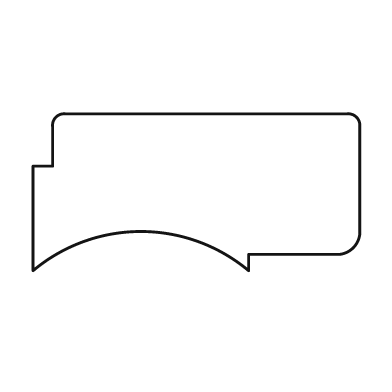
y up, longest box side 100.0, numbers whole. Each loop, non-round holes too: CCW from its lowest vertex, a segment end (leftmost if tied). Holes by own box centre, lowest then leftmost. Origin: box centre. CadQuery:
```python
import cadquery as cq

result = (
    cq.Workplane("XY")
    .moveTo(-50.0, -24.0)
    .threePointArc((-17.0, -12.0), (16.0, -24.0))
    .lineTo(16.0, -19.0)
    .lineTo(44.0, -19.0)
    .threePointArc((48.0, -17.0), (50.0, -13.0))
    .lineTo(50.0, 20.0)
    .threePointArc((49.0, 23.0), (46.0, 24.0))
    .lineTo(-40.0, 24.0)
    .threePointArc((-43.0, 23.0), (-44.0, 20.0))
    .lineTo(-44.0, 8.0)
    .lineTo(-50.0, 8.0)
    .close()
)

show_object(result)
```